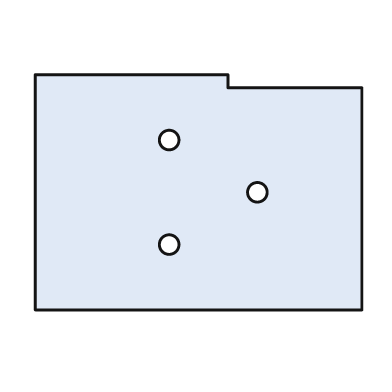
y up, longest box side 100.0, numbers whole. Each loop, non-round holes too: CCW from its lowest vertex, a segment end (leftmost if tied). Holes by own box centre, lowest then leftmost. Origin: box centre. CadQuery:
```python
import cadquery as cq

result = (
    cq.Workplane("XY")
    .moveTo(-50.0, -36.0)
    .lineTo(50.0, -36.0)
    .lineTo(50.0, 32.0)
    .lineTo(9.0, 32.0)
    .lineTo(9.0, 36.0)
    .lineTo(-50.0, 36.0)
    .close()
    .moveTo(-9.0, -16.0)
    .circle(3.0)
    .moveTo(18.0, 0.0)
    .circle(3.0)
    .moveTo(-9.0, 16.0)
    .circle(3.0)
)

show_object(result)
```